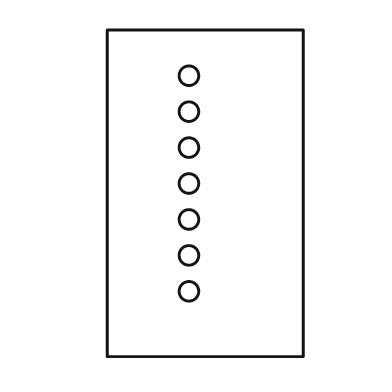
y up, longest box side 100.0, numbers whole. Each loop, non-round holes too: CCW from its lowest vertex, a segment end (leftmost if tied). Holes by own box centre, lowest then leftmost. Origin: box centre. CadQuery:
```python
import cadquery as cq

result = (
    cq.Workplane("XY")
    .moveTo(-30.0, -50.0)
    .lineTo(30.0, -50.0)
    .lineTo(30.0, 50.0)
    .lineTo(-30.0, 50.0)
    .close()
    .moveTo(-5.0, -30.0)
    .circle(3.0)
    .moveTo(-5.0, -19.0)
    .circle(3.0)
    .moveTo(-5.0, -8.0)
    .circle(3.0)
    .moveTo(-5.0, 3.0)
    .circle(3.0)
    .moveTo(-5.0, 14.0)
    .circle(3.0)
    .moveTo(-5.0, 25.0)
    .circle(3.0)
    .moveTo(-5.0, 36.0)
    .circle(3.0)
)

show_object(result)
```